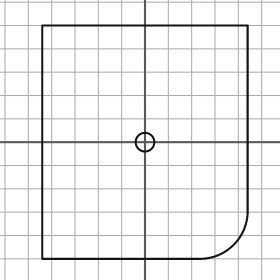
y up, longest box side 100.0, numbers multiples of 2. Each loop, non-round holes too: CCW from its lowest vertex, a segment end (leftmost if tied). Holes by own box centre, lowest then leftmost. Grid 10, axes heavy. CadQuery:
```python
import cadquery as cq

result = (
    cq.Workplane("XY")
    .moveTo(-44.0, -50.0)
    .lineTo(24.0, -50.0)
    .threePointArc((38.0, -44.0), (44.0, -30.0))
    .lineTo(44.0, 50.0)
    .lineTo(-44.0, 50.0)
    .close()
    .moveTo(0.0, 0.0)
    .circle(4.0)
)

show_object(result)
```